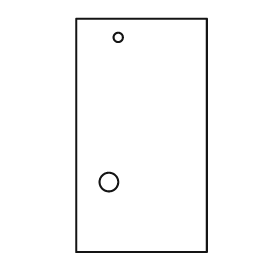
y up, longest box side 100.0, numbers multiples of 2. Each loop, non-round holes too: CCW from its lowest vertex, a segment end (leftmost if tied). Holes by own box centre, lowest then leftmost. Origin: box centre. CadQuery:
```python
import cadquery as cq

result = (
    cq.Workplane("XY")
    .moveTo(-28.0, -50.0)
    .lineTo(28.0, -50.0)
    .lineTo(28.0, 50.0)
    .lineTo(-28.0, 50.0)
    .close()
    .moveTo(-14.0, -20.0)
    .circle(4.0)
    .moveTo(-10.0, 42.0)
    .circle(2.0)
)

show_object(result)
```